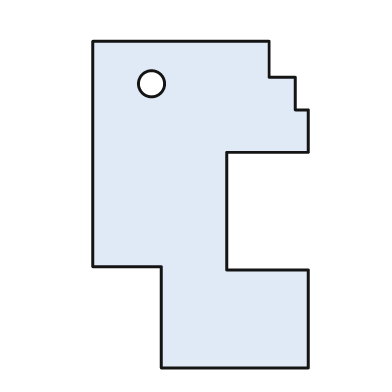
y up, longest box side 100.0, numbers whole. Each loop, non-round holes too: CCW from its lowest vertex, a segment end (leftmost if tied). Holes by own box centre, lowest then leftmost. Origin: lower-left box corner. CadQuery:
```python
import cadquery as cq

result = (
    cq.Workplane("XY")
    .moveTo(21.0, 0.0)
    .lineTo(66.0, 0.0)
    .lineTo(66.0, 30.0)
    .lineTo(41.0, 30.0)
    .lineTo(41.0, 66.0)
    .lineTo(66.0, 66.0)
    .lineTo(66.0, 79.0)
    .lineTo(62.0, 79.0)
    .lineTo(62.0, 89.0)
    .lineTo(54.0, 89.0)
    .lineTo(54.0, 100.0)
    .lineTo(0.0, 100.0)
    .lineTo(0.0, 31.0)
    .lineTo(21.0, 31.0)
    .close()
    .moveTo(18.0, 87.0)
    .circle(4.0)
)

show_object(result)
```